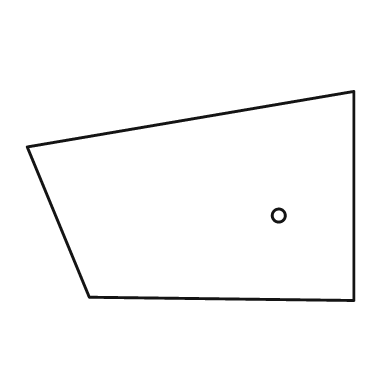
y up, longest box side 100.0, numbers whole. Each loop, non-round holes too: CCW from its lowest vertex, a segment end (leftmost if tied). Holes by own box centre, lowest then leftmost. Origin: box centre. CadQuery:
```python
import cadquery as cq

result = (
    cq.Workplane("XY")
    .moveTo(50.0, -32.0)
    .lineTo(50.0, 32.0)
    .lineTo(-50.0, 15.0)
    .lineTo(-31.0, -31.0)
    .close()
    .moveTo(27.0, -6.0)
    .circle(2.0)
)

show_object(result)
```